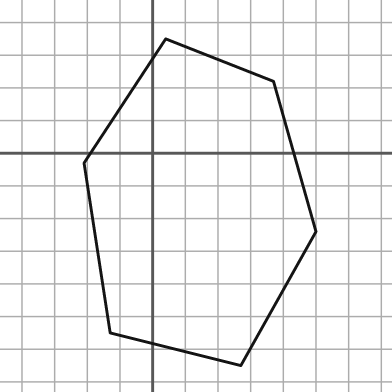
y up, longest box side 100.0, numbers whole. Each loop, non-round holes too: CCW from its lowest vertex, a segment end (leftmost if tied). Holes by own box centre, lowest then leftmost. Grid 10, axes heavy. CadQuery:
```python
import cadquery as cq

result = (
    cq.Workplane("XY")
    .moveTo(27.0, -65.0)
    .lineTo(50.0, -24.0)
    .lineTo(37.0, 22.0)
    .lineTo(4.0, 35.0)
    .lineTo(-21.0, -3.0)
    .lineTo(-13.0, -55.0)
    .close()
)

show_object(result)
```